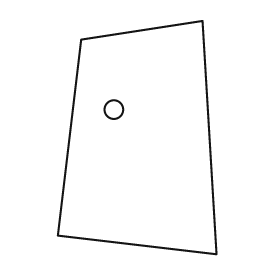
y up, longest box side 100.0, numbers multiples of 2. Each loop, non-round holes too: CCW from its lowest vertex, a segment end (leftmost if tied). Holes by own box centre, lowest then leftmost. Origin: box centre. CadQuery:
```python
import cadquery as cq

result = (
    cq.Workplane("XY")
    .moveTo(34.0, -50.0)
    .lineTo(28.0, 50.0)
    .lineTo(-24.0, 42.0)
    .lineTo(-34.0, -42.0)
    .close()
    .moveTo(-10.0, 12.0)
    .circle(4.0)
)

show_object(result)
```